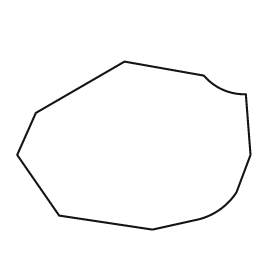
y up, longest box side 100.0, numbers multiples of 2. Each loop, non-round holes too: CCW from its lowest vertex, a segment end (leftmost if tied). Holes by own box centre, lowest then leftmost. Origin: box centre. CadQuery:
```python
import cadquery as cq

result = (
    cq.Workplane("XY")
    .moveTo(8.0, -36.0)
    .lineTo(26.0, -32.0)
    .threePointArc((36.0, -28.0), (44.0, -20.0))
    .lineTo(50.0, -4.0)
    .lineTo(48.0, 22.0)
    .threePointArc((38.0, 24.0), (30.0, 30.0))
    .lineTo(-4.0, 36.0)
    .lineTo(-42.0, 14.0)
    .lineTo(-50.0, -4.0)
    .lineTo(-32.0, -30.0)
    .close()
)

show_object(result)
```